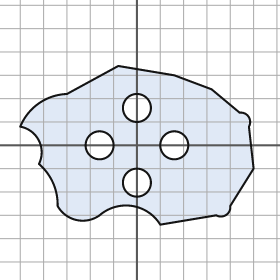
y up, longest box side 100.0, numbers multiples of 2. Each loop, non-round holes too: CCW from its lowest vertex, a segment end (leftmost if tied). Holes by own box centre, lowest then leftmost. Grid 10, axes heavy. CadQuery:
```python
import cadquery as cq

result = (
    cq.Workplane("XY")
    .moveTo(10.0, -34.0)
    .lineTo(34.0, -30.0)
    .threePointArc((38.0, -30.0), (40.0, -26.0))
    .lineTo(50.0, -10.0)
    .lineTo(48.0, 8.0)
    .threePointArc((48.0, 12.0), (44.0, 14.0))
    .lineTo(32.0, 24.0)
    .lineTo(16.0, 30.0)
    .lineTo(-8.0, 34.0)
    .lineTo(-30.0, 22.0)
    .threePointArc((-42.0, 18.0), (-50.0, 8.0))
    .threePointArc((-42.0, 2.0), (-42.0, -8.0))
    .threePointArc((-36.0, -16.0), (-34.0, -26.0))
    .threePointArc((-26.0, -32.0), (-16.0, -30.0))
    .threePointArc((-2.0, -26.0), (10.0, -34.0))
    .close()
    .moveTo(0.0, -16.0)
    .circle(6.0)
    .moveTo(-16.0, 0.0)
    .circle(6.0)
    .moveTo(16.0, 0.0)
    .circle(6.0)
    .moveTo(0.0, 16.0)
    .circle(6.0)
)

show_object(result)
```